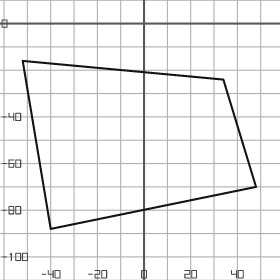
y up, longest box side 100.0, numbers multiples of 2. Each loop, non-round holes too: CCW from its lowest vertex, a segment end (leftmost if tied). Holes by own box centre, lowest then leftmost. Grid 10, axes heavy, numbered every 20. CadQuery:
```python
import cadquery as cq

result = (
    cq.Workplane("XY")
    .moveTo(-40.0, -88.0)
    .lineTo(48.0, -70.0)
    .lineTo(34.0, -24.0)
    .lineTo(-52.0, -16.0)
    .close()
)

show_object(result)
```